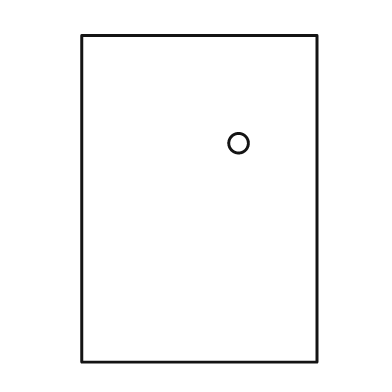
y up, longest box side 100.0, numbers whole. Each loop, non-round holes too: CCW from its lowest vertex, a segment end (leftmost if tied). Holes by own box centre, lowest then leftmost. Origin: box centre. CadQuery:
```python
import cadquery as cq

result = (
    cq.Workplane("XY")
    .moveTo(-36.0, -50.0)
    .lineTo(36.0, -50.0)
    .lineTo(36.0, 50.0)
    .lineTo(-36.0, 50.0)
    .close()
    .moveTo(12.0, 17.0)
    .circle(3.0)
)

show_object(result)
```